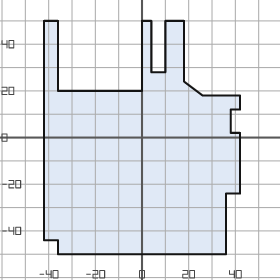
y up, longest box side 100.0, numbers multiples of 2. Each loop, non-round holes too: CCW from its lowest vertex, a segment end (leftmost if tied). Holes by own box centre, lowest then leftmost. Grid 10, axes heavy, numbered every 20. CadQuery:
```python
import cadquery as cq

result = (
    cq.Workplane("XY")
    .moveTo(-36.0, -50.0)
    .lineTo(36.0, -50.0)
    .lineTo(36.0, -24.0)
    .lineTo(42.0, -24.0)
    .lineTo(42.0, 2.0)
    .lineTo(38.0, 2.0)
    .lineTo(38.0, 12.0)
    .lineTo(42.0, 12.0)
    .lineTo(42.0, 18.0)
    .lineTo(26.0, 18.0)
    .lineTo(18.0, 24.0)
    .lineTo(18.0, 50.0)
    .lineTo(10.0, 50.0)
    .lineTo(10.0, 28.0)
    .lineTo(4.0, 28.0)
    .lineTo(4.0, 50.0)
    .lineTo(0.0, 50.0)
    .lineTo(0.0, 20.0)
    .lineTo(-36.0, 20.0)
    .lineTo(-36.0, 50.0)
    .lineTo(-42.0, 50.0)
    .lineTo(-42.0, -44.0)
    .lineTo(-36.0, -44.0)
    .close()
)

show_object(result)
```